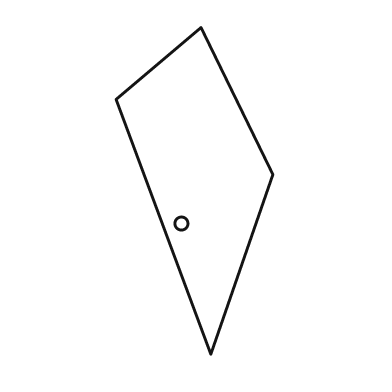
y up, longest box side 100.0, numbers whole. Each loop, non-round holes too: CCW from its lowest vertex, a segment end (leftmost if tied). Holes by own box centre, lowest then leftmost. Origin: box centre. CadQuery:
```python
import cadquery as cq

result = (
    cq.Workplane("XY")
    .moveTo(5.0, -50.0)
    .lineTo(24.0, 5.0)
    .lineTo(2.0, 50.0)
    .lineTo(-24.0, 28.0)
    .close()
    .moveTo(-4.0, -10.0)
    .circle(2.0)
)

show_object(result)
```